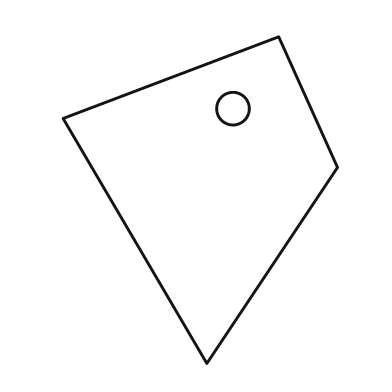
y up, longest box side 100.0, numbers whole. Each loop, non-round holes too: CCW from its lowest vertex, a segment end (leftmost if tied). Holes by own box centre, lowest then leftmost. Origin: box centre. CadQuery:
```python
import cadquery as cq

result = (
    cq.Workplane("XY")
    .moveTo(2.0, -50.0)
    .lineTo(42.0, 10.0)
    .lineTo(24.0, 50.0)
    .lineTo(-42.0, 25.0)
    .close()
    .moveTo(10.0, 28.0)
    .circle(5.0)
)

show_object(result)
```